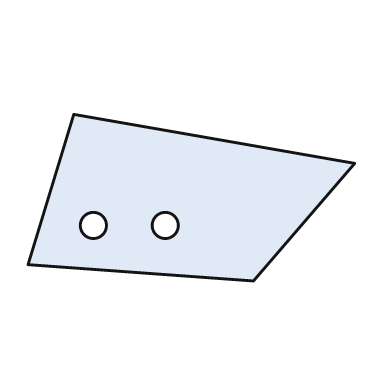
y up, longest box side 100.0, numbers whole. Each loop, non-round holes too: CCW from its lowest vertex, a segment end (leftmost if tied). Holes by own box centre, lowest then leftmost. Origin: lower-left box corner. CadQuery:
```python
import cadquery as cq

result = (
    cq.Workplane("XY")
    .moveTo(69.0, 0.0)
    .lineTo(100.0, 36.0)
    .lineTo(14.0, 51.0)
    .lineTo(0.0, 5.0)
    .close()
    .moveTo(20.0, 17.0)
    .circle(4.0)
    .moveTo(42.0, 17.0)
    .circle(4.0)
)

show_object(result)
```